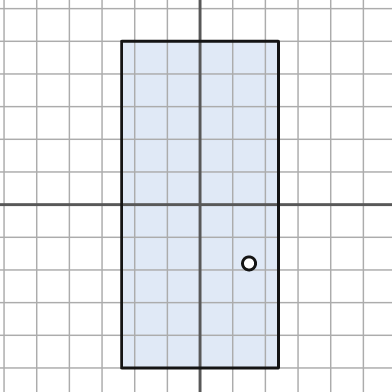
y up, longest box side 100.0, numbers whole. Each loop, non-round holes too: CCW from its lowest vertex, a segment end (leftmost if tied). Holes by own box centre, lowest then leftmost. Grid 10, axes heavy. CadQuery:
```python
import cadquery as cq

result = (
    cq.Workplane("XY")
    .moveTo(-24.0, -50.0)
    .lineTo(24.0, -50.0)
    .lineTo(24.0, 50.0)
    .lineTo(-24.0, 50.0)
    .close()
    .moveTo(15.0, -18.0)
    .circle(2.0)
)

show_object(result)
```